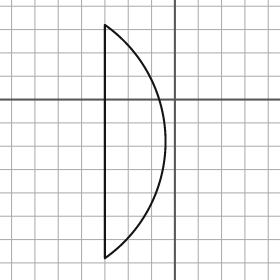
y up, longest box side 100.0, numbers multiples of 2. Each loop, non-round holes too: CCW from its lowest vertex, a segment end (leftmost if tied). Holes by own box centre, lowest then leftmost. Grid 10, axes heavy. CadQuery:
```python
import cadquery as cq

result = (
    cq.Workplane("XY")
    .moveTo(-30.0, -68.0)
    .threePointArc((-4.0, -18.0), (-30.0, 32.0))
    .close()
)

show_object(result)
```